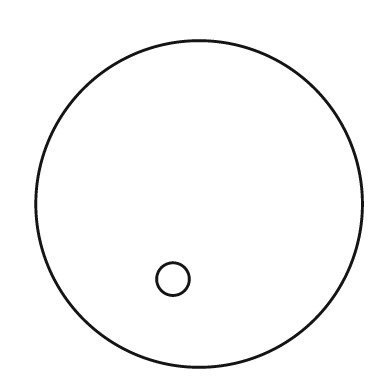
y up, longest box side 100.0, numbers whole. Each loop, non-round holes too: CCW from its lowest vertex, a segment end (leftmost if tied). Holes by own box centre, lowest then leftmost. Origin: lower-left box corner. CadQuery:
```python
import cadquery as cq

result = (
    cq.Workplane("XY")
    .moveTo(50.0, 50.0)
    .circle(50.0)
    .moveTo(42.0, 27.0)
    .circle(5.0)
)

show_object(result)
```